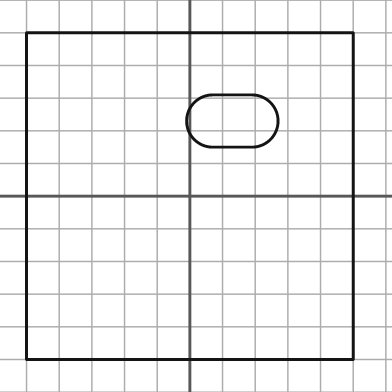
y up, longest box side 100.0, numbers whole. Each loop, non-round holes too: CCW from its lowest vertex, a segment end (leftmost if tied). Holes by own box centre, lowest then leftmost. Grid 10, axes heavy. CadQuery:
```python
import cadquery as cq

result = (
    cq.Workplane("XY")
    .moveTo(-50.0, -50.0)
    .lineTo(50.0, -50.0)
    .lineTo(50.0, 50.0)
    .lineTo(-50.0, 50.0)
    .close()
    .moveTo(7.0, 15.0)
    .lineTo(19.0, 15.0)
    .threePointArc((27.0, 23.0), (19.0, 31.0))
    .lineTo(7.0, 31.0)
    .threePointArc((-1.0, 23.0), (7.0, 15.0))
    .close()
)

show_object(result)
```